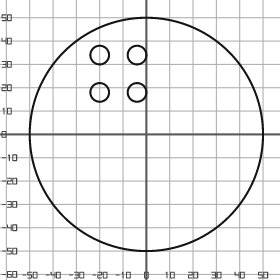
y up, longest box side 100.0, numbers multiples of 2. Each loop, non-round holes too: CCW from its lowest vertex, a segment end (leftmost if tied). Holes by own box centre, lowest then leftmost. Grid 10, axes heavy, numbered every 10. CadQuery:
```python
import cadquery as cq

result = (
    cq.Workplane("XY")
    .moveTo(0.0, 0.0)
    .circle(50.0)
    .moveTo(-20.0, 18.0)
    .circle(4.0)
    .moveTo(-4.0, 18.0)
    .circle(4.0)
    .moveTo(-20.0, 34.0)
    .circle(4.0)
    .moveTo(-4.0, 34.0)
    .circle(4.0)
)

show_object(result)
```